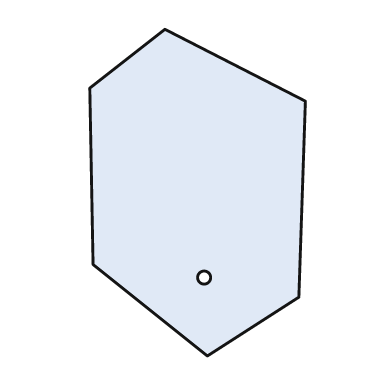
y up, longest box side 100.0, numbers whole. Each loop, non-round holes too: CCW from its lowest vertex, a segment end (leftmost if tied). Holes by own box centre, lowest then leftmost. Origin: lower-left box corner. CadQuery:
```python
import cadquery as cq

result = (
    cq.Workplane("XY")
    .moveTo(36.0, 0.0)
    .lineTo(64.0, 18.0)
    .lineTo(66.0, 78.0)
    .lineTo(23.0, 100.0)
    .lineTo(0.0, 82.0)
    .lineTo(1.0, 28.0)
    .close()
    .moveTo(35.0, 24.0)
    .circle(2.0)
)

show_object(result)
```